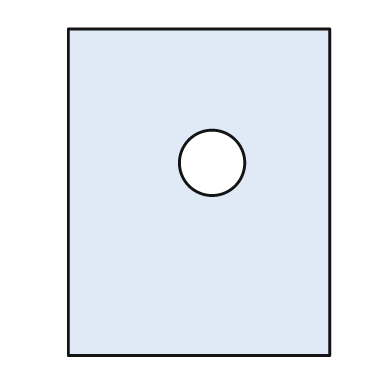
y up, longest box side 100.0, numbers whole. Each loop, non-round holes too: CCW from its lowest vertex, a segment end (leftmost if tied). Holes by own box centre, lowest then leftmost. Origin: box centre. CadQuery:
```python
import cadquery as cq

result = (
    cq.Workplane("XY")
    .moveTo(-40.0, -50.0)
    .lineTo(40.0, -50.0)
    .lineTo(40.0, 50.0)
    .lineTo(-40.0, 50.0)
    .close()
    .moveTo(4.0, 9.0)
    .circle(10.0)
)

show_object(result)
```